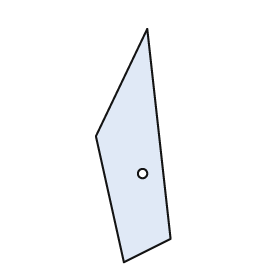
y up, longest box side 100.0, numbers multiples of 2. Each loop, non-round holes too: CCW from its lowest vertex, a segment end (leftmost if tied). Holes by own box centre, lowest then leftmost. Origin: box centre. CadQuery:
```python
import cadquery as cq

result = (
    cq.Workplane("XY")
    .moveTo(-4.0, -50.0)
    .lineTo(16.0, -40.0)
    .lineTo(6.0, 50.0)
    .lineTo(-16.0, 4.0)
    .close()
    .moveTo(4.0, -12.0)
    .circle(2.0)
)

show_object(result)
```